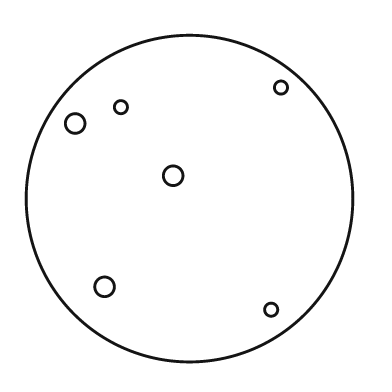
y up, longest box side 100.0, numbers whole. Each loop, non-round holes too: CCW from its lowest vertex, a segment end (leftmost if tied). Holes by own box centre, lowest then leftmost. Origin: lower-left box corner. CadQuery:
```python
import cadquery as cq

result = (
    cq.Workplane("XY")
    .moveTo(50.0, 50.0)
    .circle(50.0)
    .moveTo(75.0, 16.0)
    .circle(2.0)
    .moveTo(24.0, 23.0)
    .circle(3.0)
    .moveTo(45.0, 57.0)
    .circle(3.0)
    .moveTo(15.0, 73.0)
    .circle(3.0)
    .moveTo(29.0, 78.0)
    .circle(2.0)
    .moveTo(78.0, 84.0)
    .circle(2.0)
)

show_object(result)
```